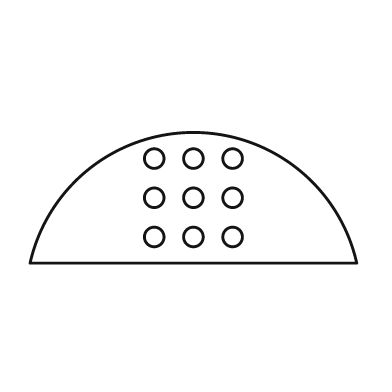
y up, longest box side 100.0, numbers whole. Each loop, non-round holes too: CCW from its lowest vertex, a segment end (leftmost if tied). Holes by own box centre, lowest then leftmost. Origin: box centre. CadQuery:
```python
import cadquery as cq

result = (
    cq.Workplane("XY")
    .moveTo(-50.0, -20.0)
    .lineTo(50.0, -20.0)
    .threePointArc((0.0, 20.0), (-50.0, -20.0))
    .close()
    .moveTo(-12.0, -12.0)
    .circle(3.0)
    .moveTo(0.0, -12.0)
    .circle(3.0)
    .moveTo(12.0, -12.0)
    .circle(3.0)
    .moveTo(-12.0, 0.0)
    .circle(3.0)
    .moveTo(0.0, 0.0)
    .circle(3.0)
    .moveTo(12.0, 0.0)
    .circle(3.0)
    .moveTo(-12.0, 12.0)
    .circle(3.0)
    .moveTo(0.0, 12.0)
    .circle(3.0)
    .moveTo(12.0, 12.0)
    .circle(3.0)
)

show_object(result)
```